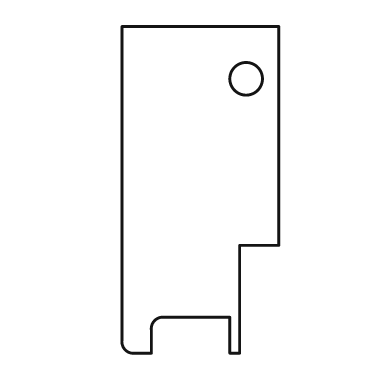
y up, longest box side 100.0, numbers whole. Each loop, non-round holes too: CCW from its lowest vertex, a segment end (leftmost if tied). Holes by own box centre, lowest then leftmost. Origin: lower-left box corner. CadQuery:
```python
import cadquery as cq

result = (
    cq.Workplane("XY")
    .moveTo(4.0, 0.0)
    .lineTo(9.0, 0.0)
    .lineTo(9.0, 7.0)
    .threePointArc((10.0, 10.0), (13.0, 11.0))
    .lineTo(33.0, 11.0)
    .lineTo(33.0, 0.0)
    .lineTo(36.0, 0.0)
    .lineTo(36.0, 33.0)
    .lineTo(48.0, 33.0)
    .lineTo(48.0, 100.0)
    .lineTo(0.0, 100.0)
    .lineTo(0.0, 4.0)
    .threePointArc((1.0, 1.0), (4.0, 0.0))
    .close()
    .moveTo(38.0, 84.0)
    .circle(5.0)
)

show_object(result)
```